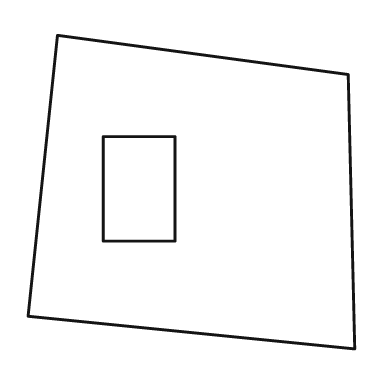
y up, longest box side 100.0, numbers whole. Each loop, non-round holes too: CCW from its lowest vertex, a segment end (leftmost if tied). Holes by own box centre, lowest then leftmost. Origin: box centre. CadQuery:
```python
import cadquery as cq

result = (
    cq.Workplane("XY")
    .moveTo(50.0, -48.0)
    .lineTo(48.0, 36.0)
    .lineTo(-41.0, 48.0)
    .lineTo(-50.0, -38.0)
    .close()
    .moveTo(-27.0, -15.0)
    .lineTo(-5.0, -15.0)
    .lineTo(-5.0, 17.0)
    .lineTo(-27.0, 17.0)
    .close()
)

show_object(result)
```